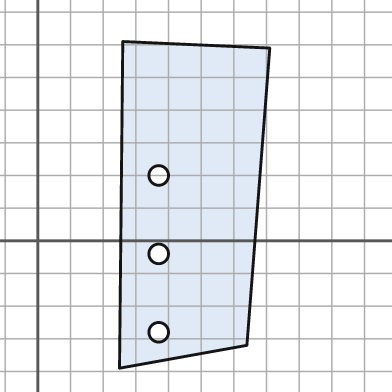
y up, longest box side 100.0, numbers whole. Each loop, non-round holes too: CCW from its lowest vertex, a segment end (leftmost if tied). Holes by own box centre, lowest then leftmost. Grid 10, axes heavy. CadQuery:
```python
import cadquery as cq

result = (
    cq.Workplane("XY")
    .moveTo(25.0, -39.0)
    .lineTo(64.0, -32.0)
    .lineTo(71.0, 59.0)
    .lineTo(26.0, 61.0)
    .close()
    .moveTo(37.0, -28.0)
    .circle(3.0)
    .moveTo(37.0, -4.0)
    .circle(3.0)
    .moveTo(37.0, 20.0)
    .circle(3.0)
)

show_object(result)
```